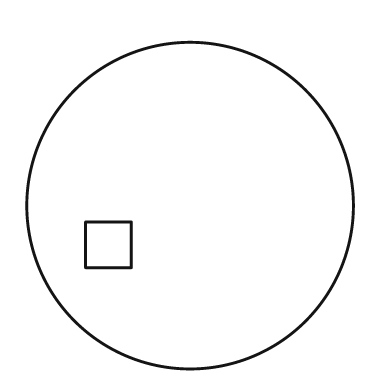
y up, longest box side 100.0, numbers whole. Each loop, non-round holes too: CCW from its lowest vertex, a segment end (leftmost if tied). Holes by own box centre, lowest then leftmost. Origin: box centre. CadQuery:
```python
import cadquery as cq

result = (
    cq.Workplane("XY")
    .moveTo(0.0, 0.0)
    .circle(50.0)
    .moveTo(-32.0, -19.0)
    .lineTo(-18.0, -19.0)
    .lineTo(-18.0, -5.0)
    .lineTo(-32.0, -5.0)
    .close()
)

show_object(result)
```